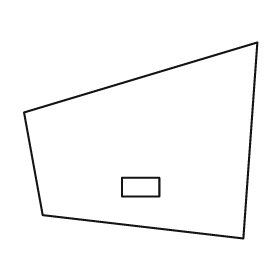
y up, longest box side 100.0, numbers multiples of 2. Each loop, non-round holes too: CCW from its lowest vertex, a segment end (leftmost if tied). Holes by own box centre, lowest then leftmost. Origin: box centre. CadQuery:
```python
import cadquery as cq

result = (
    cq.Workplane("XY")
    .moveTo(44.0, -42.0)
    .lineTo(50.0, 42.0)
    .lineTo(-50.0, 12.0)
    .lineTo(-42.0, -32.0)
    .close()
    .moveTo(-8.0, -24.0)
    .lineTo(8.0, -24.0)
    .lineTo(8.0, -16.0)
    .lineTo(-8.0, -16.0)
    .close()
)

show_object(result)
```